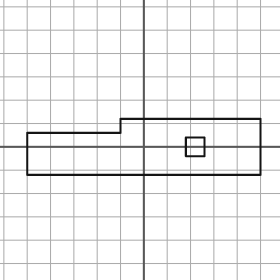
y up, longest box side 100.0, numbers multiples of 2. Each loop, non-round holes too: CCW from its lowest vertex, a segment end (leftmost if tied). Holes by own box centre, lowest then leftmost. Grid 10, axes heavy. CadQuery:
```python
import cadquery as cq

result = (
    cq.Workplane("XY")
    .moveTo(-50.0, -12.0)
    .lineTo(50.0, -12.0)
    .lineTo(50.0, 12.0)
    .lineTo(-10.0, 12.0)
    .lineTo(-10.0, 6.0)
    .lineTo(-50.0, 6.0)
    .close()
    .moveTo(18.0, -4.0)
    .lineTo(26.0, -4.0)
    .lineTo(26.0, 4.0)
    .lineTo(18.0, 4.0)
    .close()
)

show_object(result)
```